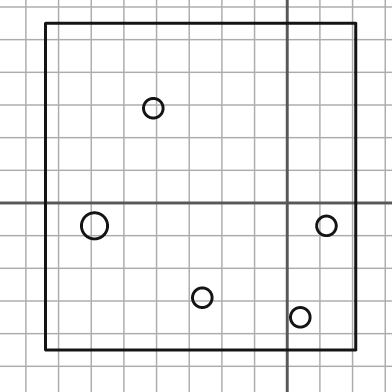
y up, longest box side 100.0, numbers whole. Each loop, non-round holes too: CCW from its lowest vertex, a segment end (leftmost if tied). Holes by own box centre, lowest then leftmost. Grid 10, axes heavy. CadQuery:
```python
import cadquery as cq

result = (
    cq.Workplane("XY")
    .moveTo(-74.0, -45.0)
    .lineTo(21.0, -45.0)
    .lineTo(21.0, 55.0)
    .lineTo(-74.0, 55.0)
    .close()
    .moveTo(4.0, -35.0)
    .circle(3.0)
    .moveTo(-26.0, -29.0)
    .circle(3.0)
    .moveTo(-59.0, -7.0)
    .circle(4.0)
    .moveTo(12.0, -7.0)
    .circle(3.0)
    .moveTo(-41.0, 29.0)
    .circle(3.0)
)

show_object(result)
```